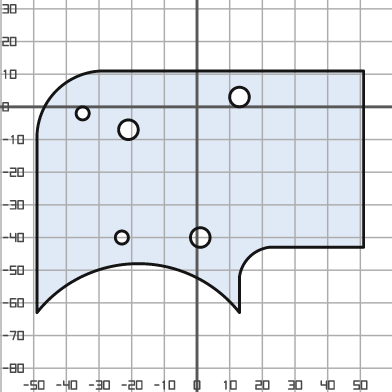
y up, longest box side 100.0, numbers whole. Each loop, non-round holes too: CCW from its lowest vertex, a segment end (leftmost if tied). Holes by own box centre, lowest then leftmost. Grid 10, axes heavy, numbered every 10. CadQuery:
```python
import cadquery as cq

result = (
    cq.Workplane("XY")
    .moveTo(-49.0, -63.0)
    .threePointArc((-18.0, -48.0), (13.0, -63.0))
    .lineTo(13.0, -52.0)
    .threePointArc((16.0, -46.0), (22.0, -43.0))
    .lineTo(51.0, -43.0)
    .lineTo(51.0, 11.0)
    .lineTo(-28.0, 11.0)
    .threePointArc((-43.0, 5.0), (-49.0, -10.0))
    .close()
    .moveTo(-23.0, -40.0)
    .circle(2.0)
    .moveTo(1.0, -40.0)
    .circle(3.0)
    .moveTo(-21.0, -7.0)
    .circle(3.0)
    .moveTo(-35.0, -2.0)
    .circle(2.0)
    .moveTo(13.0, 3.0)
    .circle(3.0)
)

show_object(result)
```